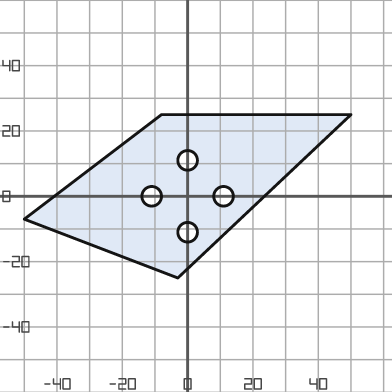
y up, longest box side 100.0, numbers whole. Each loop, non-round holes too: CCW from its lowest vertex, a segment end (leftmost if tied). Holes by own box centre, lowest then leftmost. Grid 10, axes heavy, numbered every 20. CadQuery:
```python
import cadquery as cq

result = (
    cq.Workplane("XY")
    .moveTo(-3.0, -25.0)
    .lineTo(50.0, 25.0)
    .lineTo(-8.0, 25.0)
    .lineTo(-50.0, -7.0)
    .close()
    .moveTo(0.0, -11.0)
    .circle(3.0)
    .moveTo(-11.0, 0.0)
    .circle(3.0)
    .moveTo(11.0, 0.0)
    .circle(3.0)
    .moveTo(0.0, 11.0)
    .circle(3.0)
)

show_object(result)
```